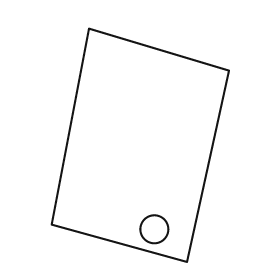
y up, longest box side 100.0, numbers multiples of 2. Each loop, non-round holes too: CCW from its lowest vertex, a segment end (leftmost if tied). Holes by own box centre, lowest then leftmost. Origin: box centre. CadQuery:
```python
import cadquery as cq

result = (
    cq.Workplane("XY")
    .moveTo(20.0, -50.0)
    .lineTo(38.0, 32.0)
    .lineTo(-22.0, 50.0)
    .lineTo(-38.0, -34.0)
    .close()
    .moveTo(6.0, -36.0)
    .circle(6.0)
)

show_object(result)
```